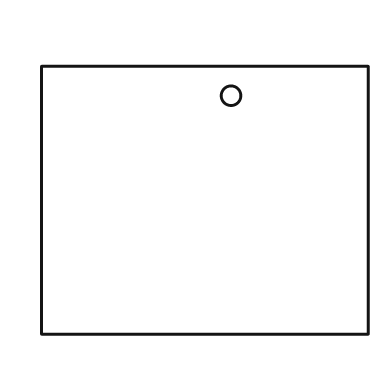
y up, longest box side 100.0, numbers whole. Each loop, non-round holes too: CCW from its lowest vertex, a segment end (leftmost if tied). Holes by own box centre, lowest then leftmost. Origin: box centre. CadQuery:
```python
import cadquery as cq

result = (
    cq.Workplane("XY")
    .moveTo(-50.0, -41.0)
    .lineTo(50.0, -41.0)
    .lineTo(50.0, 41.0)
    .lineTo(-50.0, 41.0)
    .close()
    .moveTo(8.0, 32.0)
    .circle(3.0)
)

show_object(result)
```